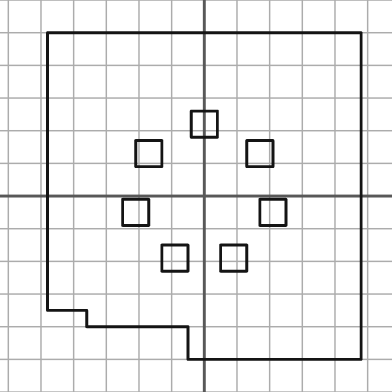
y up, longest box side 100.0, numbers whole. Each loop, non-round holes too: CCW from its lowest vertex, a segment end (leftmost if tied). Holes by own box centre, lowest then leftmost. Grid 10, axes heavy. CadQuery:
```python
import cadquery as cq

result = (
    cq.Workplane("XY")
    .moveTo(-5.0, -50.0)
    .lineTo(48.0, -50.0)
    .lineTo(48.0, 50.0)
    .lineTo(-48.0, 50.0)
    .lineTo(-48.0, -35.0)
    .lineTo(-36.0, -35.0)
    .lineTo(-36.0, -40.0)
    .lineTo(-5.0, -40.0)
    .close()
    .moveTo(-13.0, -23.0)
    .lineTo(-5.0, -23.0)
    .lineTo(-5.0, -15.0)
    .lineTo(-13.0, -15.0)
    .close()
    .moveTo(5.0, -23.0)
    .lineTo(13.0, -23.0)
    .lineTo(13.0, -15.0)
    .lineTo(5.0, -15.0)
    .close()
    .moveTo(-25.0, -9.0)
    .lineTo(-17.0, -9.0)
    .lineTo(-17.0, -1.0)
    .lineTo(-25.0, -1.0)
    .close()
    .moveTo(17.0, -9.0)
    .lineTo(25.0, -9.0)
    .lineTo(25.0, -1.0)
    .lineTo(17.0, -1.0)
    .close()
    .moveTo(-21.0, 9.0)
    .lineTo(-13.0, 9.0)
    .lineTo(-13.0, 17.0)
    .lineTo(-21.0, 17.0)
    .close()
    .moveTo(13.0, 9.0)
    .lineTo(21.0, 9.0)
    .lineTo(21.0, 17.0)
    .lineTo(13.0, 17.0)
    .close()
    .moveTo(-4.0, 18.0)
    .lineTo(4.0, 18.0)
    .lineTo(4.0, 26.0)
    .lineTo(-4.0, 26.0)
    .close()
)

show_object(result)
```